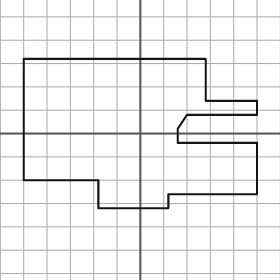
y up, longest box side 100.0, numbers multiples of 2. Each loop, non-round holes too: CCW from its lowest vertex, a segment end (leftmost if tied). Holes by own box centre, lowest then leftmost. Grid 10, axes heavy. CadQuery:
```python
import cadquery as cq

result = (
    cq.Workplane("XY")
    .moveTo(-18.0, -32.0)
    .lineTo(12.0, -32.0)
    .lineTo(12.0, -26.0)
    .lineTo(50.0, -26.0)
    .lineTo(50.0, -4.0)
    .lineTo(16.0, -4.0)
    .lineTo(16.0, 2.0)
    .lineTo(20.0, 8.0)
    .lineTo(50.0, 8.0)
    .lineTo(50.0, 14.0)
    .lineTo(28.0, 14.0)
    .lineTo(28.0, 32.0)
    .lineTo(-50.0, 32.0)
    .lineTo(-50.0, -20.0)
    .lineTo(-18.0, -20.0)
    .close()
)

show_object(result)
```